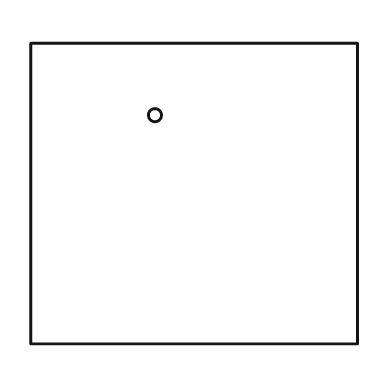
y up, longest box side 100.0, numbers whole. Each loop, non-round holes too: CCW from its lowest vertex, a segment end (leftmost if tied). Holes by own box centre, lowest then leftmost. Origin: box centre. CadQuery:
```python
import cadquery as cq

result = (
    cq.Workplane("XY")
    .moveTo(-50.0, -46.0)
    .lineTo(50.0, -46.0)
    .lineTo(50.0, 46.0)
    .lineTo(-50.0, 46.0)
    .close()
    .moveTo(-12.0, 24.0)
    .circle(2.0)
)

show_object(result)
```